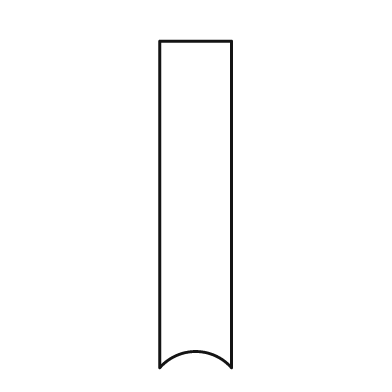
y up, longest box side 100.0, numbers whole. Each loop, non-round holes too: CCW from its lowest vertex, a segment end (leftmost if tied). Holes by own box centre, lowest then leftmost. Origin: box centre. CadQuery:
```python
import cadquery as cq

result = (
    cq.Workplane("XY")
    .moveTo(-11.0, -50.0)
    .threePointArc((0.0, -45.0), (11.0, -50.0))
    .lineTo(11.0, 50.0)
    .lineTo(-11.0, 50.0)
    .close()
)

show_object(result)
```